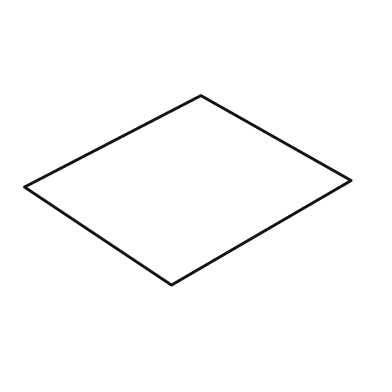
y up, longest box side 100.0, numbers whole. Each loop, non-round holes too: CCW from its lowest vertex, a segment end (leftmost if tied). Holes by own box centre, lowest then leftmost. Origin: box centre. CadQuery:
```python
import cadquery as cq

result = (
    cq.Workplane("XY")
    .moveTo(-5.0, -29.0)
    .lineTo(50.0, 3.0)
    .lineTo(4.0, 29.0)
    .lineTo(-50.0, 1.0)
    .close()
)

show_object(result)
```